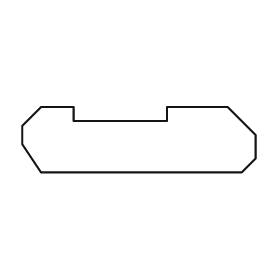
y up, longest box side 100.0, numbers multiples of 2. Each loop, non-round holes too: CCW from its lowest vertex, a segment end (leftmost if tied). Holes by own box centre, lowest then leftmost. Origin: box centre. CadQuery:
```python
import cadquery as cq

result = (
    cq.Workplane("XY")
    .moveTo(-42.0, -14.0)
    .lineTo(44.0, -14.0)
    .lineTo(50.0, -8.0)
    .lineTo(50.0, 2.0)
    .lineTo(38.0, 14.0)
    .lineTo(12.0, 14.0)
    .lineTo(12.0, 8.0)
    .lineTo(-28.0, 8.0)
    .lineTo(-28.0, 14.0)
    .lineTo(-42.0, 14.0)
    .lineTo(-50.0, 6.0)
    .lineTo(-50.0, -2.0)
    .close()
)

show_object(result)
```